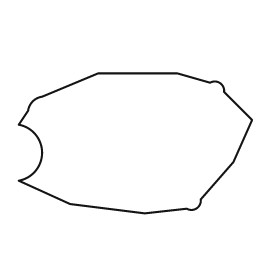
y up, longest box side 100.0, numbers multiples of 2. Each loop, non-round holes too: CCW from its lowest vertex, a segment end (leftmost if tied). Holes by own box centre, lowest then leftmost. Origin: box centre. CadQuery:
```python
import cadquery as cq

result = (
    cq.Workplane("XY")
    .moveTo(4.0, -30.0)
    .lineTo(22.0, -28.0)
    .threePointArc((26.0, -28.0), (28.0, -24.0))
    .lineTo(42.0, -8.0)
    .lineTo(50.0, 10.0)
    .lineTo(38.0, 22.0)
    .threePointArc((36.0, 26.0), (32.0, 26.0))
    .lineTo(18.0, 30.0)
    .lineTo(-16.0, 30.0)
    .lineTo(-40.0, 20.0)
    .threePointArc((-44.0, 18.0), (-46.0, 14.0))
    .lineTo(-50.0, 8.0)
    .threePointArc((-40.0, -4.0), (-50.0, -16.0))
    .lineTo(-28.0, -26.0)
    .close()
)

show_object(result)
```